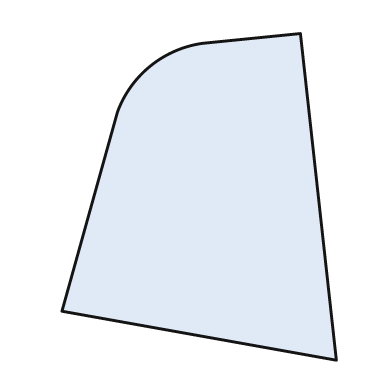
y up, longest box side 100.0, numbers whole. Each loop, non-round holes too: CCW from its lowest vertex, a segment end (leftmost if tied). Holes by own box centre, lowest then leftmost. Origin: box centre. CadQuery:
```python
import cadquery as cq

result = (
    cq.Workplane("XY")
    .moveTo(42.0, -50.0)
    .lineTo(31.0, 50.0)
    .lineTo(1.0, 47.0)
    .threePointArc((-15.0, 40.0), (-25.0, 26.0))
    .lineTo(-42.0, -35.0)
    .close()
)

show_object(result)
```